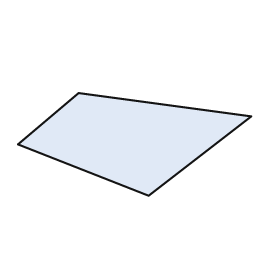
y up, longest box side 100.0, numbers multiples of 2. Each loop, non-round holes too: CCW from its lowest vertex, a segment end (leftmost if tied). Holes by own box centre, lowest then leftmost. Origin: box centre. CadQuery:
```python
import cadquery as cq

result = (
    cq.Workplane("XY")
    .moveTo(6.0, -22.0)
    .lineTo(50.0, 12.0)
    .lineTo(-24.0, 22.0)
    .lineTo(-50.0, 0.0)
    .close()
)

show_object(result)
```